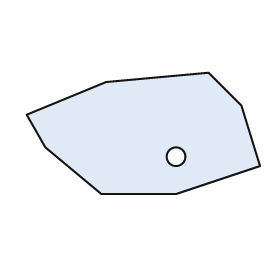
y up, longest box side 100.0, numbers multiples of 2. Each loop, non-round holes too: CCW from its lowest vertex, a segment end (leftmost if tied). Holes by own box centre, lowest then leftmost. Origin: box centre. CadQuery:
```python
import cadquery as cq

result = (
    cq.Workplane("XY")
    .moveTo(-18.0, -26.0)
    .lineTo(14.0, -26.0)
    .lineTo(50.0, -14.0)
    .lineTo(42.0, 12.0)
    .lineTo(28.0, 26.0)
    .lineTo(-16.0, 22.0)
    .lineTo(-50.0, 8.0)
    .lineTo(-42.0, -6.0)
    .close()
    .moveTo(14.0, -10.0)
    .circle(4.0)
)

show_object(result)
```